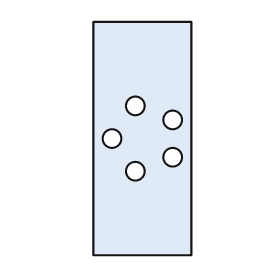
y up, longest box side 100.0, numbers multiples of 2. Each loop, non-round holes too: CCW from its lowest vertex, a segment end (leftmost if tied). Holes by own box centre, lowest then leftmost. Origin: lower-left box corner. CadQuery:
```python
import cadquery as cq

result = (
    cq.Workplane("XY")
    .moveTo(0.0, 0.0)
    .lineTo(42.0, 0.0)
    .lineTo(42.0, 100.0)
    .lineTo(0.0, 100.0)
    .close()
    .moveTo(18.0, 36.0)
    .circle(4.0)
    .moveTo(34.0, 42.0)
    .circle(4.0)
    .moveTo(8.0, 50.0)
    .circle(4.0)
    .moveTo(34.0, 58.0)
    .circle(4.0)
    .moveTo(18.0, 64.0)
    .circle(4.0)
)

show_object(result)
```